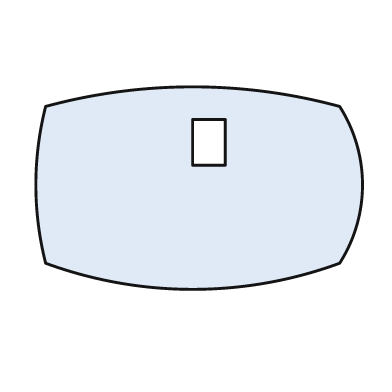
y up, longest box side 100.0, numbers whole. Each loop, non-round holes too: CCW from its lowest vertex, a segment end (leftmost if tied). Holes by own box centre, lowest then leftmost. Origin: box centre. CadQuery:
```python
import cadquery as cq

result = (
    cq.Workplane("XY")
    .moveTo(-47.0, -23.0)
    .threePointArc((-2.0, -31.0), (43.0, -23.0))
    .threePointArc((50.0, 1.0), (43.0, 25.0))
    .threePointArc((-2.0, 31.0), (-47.0, 25.0))
    .threePointArc((-50.0, 1.0), (-47.0, -23.0))
    .close()
    .moveTo(-2.0, 7.0)
    .lineTo(8.0, 7.0)
    .lineTo(8.0, 21.0)
    .lineTo(-2.0, 21.0)
    .close()
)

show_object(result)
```